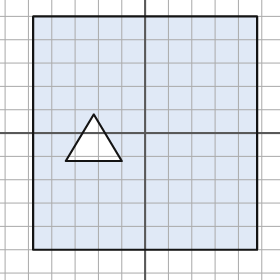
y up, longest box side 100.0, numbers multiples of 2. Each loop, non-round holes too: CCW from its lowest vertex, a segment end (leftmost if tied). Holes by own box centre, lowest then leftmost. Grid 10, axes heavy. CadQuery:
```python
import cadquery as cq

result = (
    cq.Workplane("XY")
    .moveTo(-48.0, -50.0)
    .lineTo(48.0, -50.0)
    .lineTo(48.0, 50.0)
    .lineTo(-48.0, 50.0)
    .close()
    .moveTo(-34.0, -12.0)
    .lineTo(-10.0, -12.0)
    .lineTo(-22.0, 8.0)
    .close()
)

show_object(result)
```